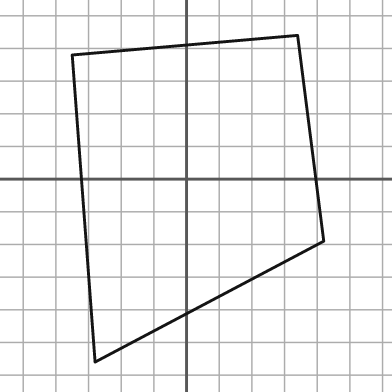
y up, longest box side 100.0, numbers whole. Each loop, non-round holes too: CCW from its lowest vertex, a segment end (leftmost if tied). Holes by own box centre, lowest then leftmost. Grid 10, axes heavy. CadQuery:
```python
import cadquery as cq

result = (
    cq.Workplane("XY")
    .moveTo(-28.0, -56.0)
    .lineTo(42.0, -19.0)
    .lineTo(34.0, 44.0)
    .lineTo(-35.0, 38.0)
    .close()
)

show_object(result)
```